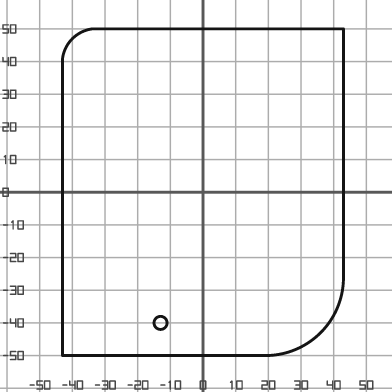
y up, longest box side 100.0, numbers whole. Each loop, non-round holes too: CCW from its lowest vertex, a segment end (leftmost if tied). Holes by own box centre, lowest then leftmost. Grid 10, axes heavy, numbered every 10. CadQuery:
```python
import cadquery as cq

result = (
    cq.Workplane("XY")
    .moveTo(-43.0, -50.0)
    .lineTo(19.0, -50.0)
    .threePointArc((36.0, -43.0), (43.0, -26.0))
    .lineTo(43.0, 50.0)
    .lineTo(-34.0, 50.0)
    .threePointArc((-40.0, 47.0), (-43.0, 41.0))
    .close()
    .moveTo(-13.0, -40.0)
    .circle(2.0)
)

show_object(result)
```